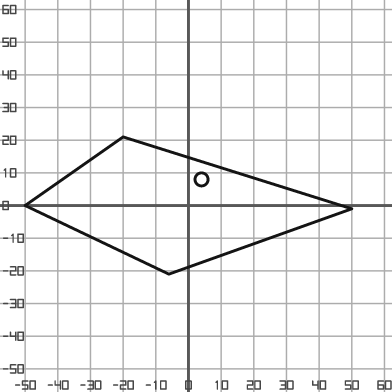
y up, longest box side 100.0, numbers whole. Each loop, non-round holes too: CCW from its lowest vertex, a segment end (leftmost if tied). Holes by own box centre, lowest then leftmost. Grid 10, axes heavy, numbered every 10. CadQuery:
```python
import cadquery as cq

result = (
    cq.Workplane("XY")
    .moveTo(-6.0, -21.0)
    .lineTo(50.0, -1.0)
    .lineTo(-20.0, 21.0)
    .lineTo(-50.0, 0.0)
    .close()
    .moveTo(4.0, 8.0)
    .circle(2.0)
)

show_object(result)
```